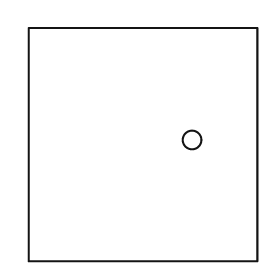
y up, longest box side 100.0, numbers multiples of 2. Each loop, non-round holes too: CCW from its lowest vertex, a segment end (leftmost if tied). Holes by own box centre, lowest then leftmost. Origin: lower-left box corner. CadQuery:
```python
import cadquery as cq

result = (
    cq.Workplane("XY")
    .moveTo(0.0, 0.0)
    .lineTo(98.0, 0.0)
    .lineTo(98.0, 100.0)
    .lineTo(0.0, 100.0)
    .close()
    .moveTo(70.0, 52.0)
    .circle(4.0)
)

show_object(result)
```